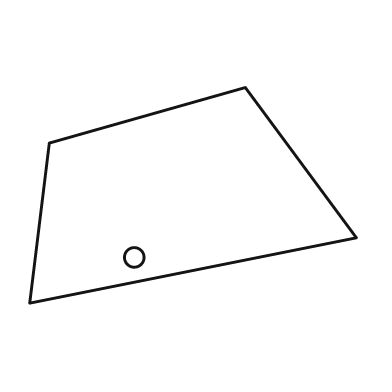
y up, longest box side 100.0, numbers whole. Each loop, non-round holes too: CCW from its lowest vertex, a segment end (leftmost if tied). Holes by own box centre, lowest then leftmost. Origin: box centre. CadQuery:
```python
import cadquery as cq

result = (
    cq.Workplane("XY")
    .moveTo(-50.0, -33.0)
    .lineTo(50.0, -13.0)
    .lineTo(16.0, 33.0)
    .lineTo(-44.0, 16.0)
    .close()
    .moveTo(-18.0, -19.0)
    .circle(3.0)
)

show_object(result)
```